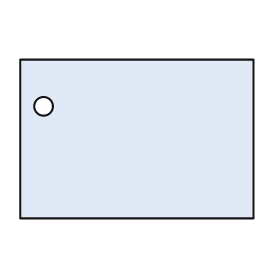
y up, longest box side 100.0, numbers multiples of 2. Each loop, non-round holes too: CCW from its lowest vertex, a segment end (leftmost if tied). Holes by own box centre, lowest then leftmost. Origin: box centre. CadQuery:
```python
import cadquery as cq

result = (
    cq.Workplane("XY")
    .moveTo(-50.0, -34.0)
    .lineTo(50.0, -34.0)
    .lineTo(50.0, 34.0)
    .lineTo(-50.0, 34.0)
    .close()
    .moveTo(-40.0, 14.0)
    .circle(4.0)
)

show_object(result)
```